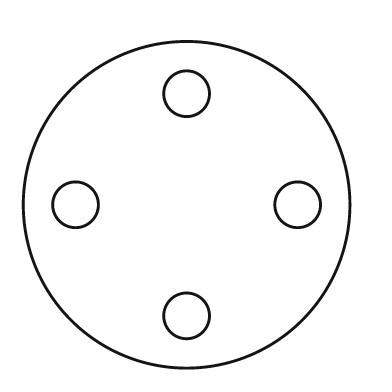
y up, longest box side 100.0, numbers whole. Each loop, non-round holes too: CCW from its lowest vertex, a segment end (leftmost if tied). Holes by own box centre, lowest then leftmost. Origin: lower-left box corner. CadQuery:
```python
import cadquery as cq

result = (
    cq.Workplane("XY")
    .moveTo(50.0, 50.0)
    .circle(50.0)
    .moveTo(50.0, 16.0)
    .circle(7.0)
    .moveTo(16.0, 50.0)
    .circle(7.0)
    .moveTo(84.0, 50.0)
    .circle(7.0)
    .moveTo(50.0, 84.0)
    .circle(7.0)
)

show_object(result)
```